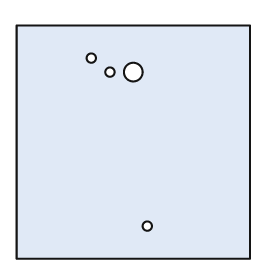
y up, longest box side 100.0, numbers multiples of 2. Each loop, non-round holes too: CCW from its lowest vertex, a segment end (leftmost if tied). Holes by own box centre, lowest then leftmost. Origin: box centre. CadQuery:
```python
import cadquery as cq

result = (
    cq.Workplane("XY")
    .moveTo(-50.0, -50.0)
    .lineTo(50.0, -50.0)
    .lineTo(50.0, 50.0)
    .lineTo(-50.0, 50.0)
    .close()
    .moveTo(6.0, -36.0)
    .circle(2.0)
    .moveTo(-10.0, 30.0)
    .circle(2.0)
    .moveTo(0.0, 30.0)
    .circle(4.0)
    .moveTo(-18.0, 36.0)
    .circle(2.0)
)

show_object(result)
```